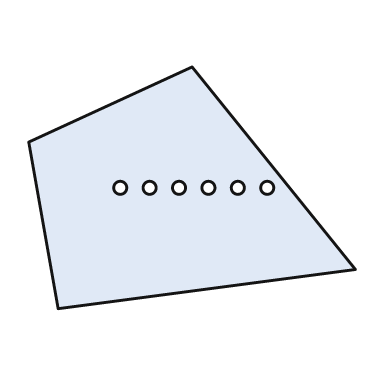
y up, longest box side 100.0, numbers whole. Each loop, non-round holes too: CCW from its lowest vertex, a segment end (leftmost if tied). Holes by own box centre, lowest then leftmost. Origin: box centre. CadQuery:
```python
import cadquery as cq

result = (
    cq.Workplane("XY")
    .moveTo(-41.0, -37.0)
    .lineTo(50.0, -25.0)
    .lineTo(0.0, 37.0)
    .lineTo(-50.0, 14.0)
    .close()
    .moveTo(-22.0, 0.0)
    .circle(2.0)
    .moveTo(-13.0, 0.0)
    .circle(2.0)
    .moveTo(-4.0, 0.0)
    .circle(2.0)
    .moveTo(5.0, 0.0)
    .circle(2.0)
    .moveTo(14.0, 0.0)
    .circle(2.0)
    .moveTo(23.0, 0.0)
    .circle(2.0)
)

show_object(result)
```